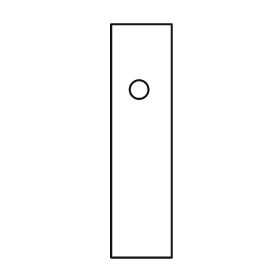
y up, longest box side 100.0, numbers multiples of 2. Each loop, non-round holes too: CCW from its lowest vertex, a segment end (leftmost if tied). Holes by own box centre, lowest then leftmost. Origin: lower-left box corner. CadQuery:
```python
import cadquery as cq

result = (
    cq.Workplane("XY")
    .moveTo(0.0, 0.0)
    .lineTo(26.0, 0.0)
    .lineTo(26.0, 100.0)
    .lineTo(0.0, 100.0)
    .close()
    .moveTo(12.0, 72.0)
    .circle(4.0)
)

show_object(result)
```